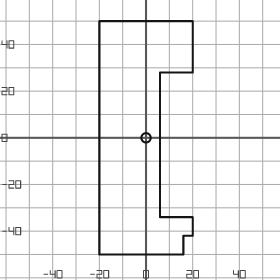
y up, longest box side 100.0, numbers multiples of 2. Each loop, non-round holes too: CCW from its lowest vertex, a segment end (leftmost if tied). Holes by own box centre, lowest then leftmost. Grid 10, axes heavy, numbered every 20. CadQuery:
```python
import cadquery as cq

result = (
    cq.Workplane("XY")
    .moveTo(-20.0, -50.0)
    .lineTo(16.0, -50.0)
    .lineTo(16.0, -42.0)
    .lineTo(20.0, -42.0)
    .lineTo(20.0, -34.0)
    .lineTo(6.0, -34.0)
    .lineTo(6.0, 28.0)
    .lineTo(20.0, 28.0)
    .lineTo(20.0, 50.0)
    .lineTo(-20.0, 50.0)
    .close()
    .moveTo(0.0, 0.0)
    .circle(2.0)
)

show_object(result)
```